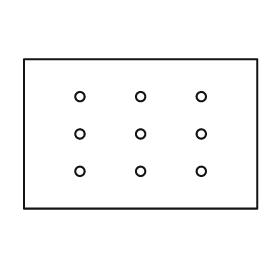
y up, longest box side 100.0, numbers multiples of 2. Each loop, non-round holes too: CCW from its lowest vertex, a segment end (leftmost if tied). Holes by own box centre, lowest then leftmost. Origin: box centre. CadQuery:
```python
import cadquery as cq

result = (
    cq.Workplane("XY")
    .moveTo(-50.0, -32.0)
    .lineTo(50.0, -32.0)
    .lineTo(50.0, 32.0)
    .lineTo(-50.0, 32.0)
    .close()
    .moveTo(-26.0, -16.0)
    .circle(2.0)
    .moveTo(0.0, -16.0)
    .circle(2.0)
    .moveTo(26.0, -16.0)
    .circle(2.0)
    .moveTo(-26.0, 0.0)
    .circle(2.0)
    .moveTo(0.0, 0.0)
    .circle(2.0)
    .moveTo(26.0, 0.0)
    .circle(2.0)
    .moveTo(-26.0, 16.0)
    .circle(2.0)
    .moveTo(0.0, 16.0)
    .circle(2.0)
    .moveTo(26.0, 16.0)
    .circle(2.0)
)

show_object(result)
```